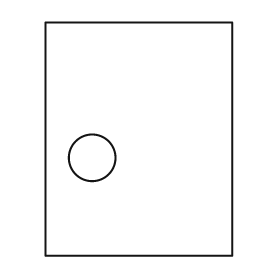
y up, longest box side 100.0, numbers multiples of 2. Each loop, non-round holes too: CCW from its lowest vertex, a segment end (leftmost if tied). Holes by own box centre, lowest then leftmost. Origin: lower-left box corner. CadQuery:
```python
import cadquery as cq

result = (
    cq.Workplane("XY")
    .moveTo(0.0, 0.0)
    .lineTo(80.0, 0.0)
    .lineTo(80.0, 100.0)
    .lineTo(0.0, 100.0)
    .close()
    .moveTo(20.0, 42.0)
    .circle(10.0)
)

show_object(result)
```